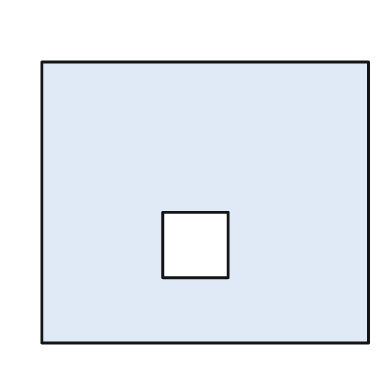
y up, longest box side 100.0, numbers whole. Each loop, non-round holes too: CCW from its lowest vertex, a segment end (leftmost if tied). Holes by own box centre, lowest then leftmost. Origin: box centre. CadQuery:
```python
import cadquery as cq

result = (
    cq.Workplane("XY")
    .moveTo(-50.0, -43.0)
    .lineTo(50.0, -43.0)
    .lineTo(50.0, 43.0)
    .lineTo(-50.0, 43.0)
    .close()
    .moveTo(-13.0, -23.0)
    .lineTo(7.0, -23.0)
    .lineTo(7.0, -3.0)
    .lineTo(-13.0, -3.0)
    .close()
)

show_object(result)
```